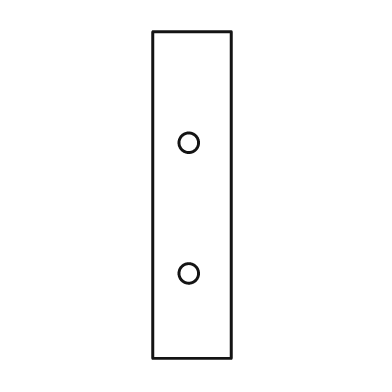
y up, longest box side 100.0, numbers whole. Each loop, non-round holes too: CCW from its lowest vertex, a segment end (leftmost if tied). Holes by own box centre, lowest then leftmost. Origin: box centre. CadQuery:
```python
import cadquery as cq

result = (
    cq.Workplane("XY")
    .moveTo(-12.0, -50.0)
    .lineTo(12.0, -50.0)
    .lineTo(12.0, 50.0)
    .lineTo(-12.0, 50.0)
    .close()
    .moveTo(-1.0, -24.0)
    .circle(3.0)
    .moveTo(-1.0, 16.0)
    .circle(3.0)
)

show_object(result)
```